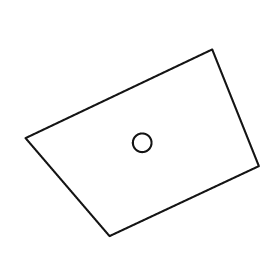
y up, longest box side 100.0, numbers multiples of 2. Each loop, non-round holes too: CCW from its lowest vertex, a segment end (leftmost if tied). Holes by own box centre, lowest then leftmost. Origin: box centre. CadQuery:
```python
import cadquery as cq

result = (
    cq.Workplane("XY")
    .moveTo(-14.0, -40.0)
    .lineTo(50.0, -10.0)
    .lineTo(30.0, 40.0)
    .lineTo(-50.0, 2.0)
    .close()
    .moveTo(0.0, 0.0)
    .circle(4.0)
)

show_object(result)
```